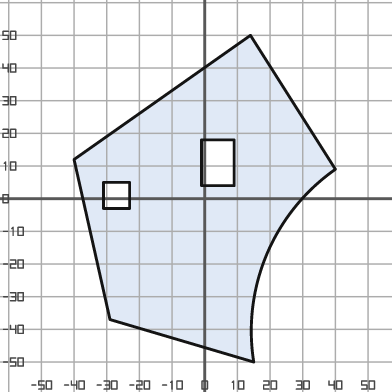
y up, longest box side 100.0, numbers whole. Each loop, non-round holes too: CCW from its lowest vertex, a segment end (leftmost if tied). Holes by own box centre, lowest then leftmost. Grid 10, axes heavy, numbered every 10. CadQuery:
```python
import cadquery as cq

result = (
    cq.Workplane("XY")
    .moveTo(15.0, -50.0)
    .threePointArc((19.0, -17.0), (40.0, 9.0))
    .lineTo(14.0, 50.0)
    .lineTo(-40.0, 12.0)
    .lineTo(-29.0, -37.0)
    .close()
    .moveTo(-31.0, -3.0)
    .lineTo(-23.0, -3.0)
    .lineTo(-23.0, 5.0)
    .lineTo(-31.0, 5.0)
    .close()
    .moveTo(-1.0, 4.0)
    .lineTo(9.0, 4.0)
    .lineTo(9.0, 18.0)
    .lineTo(-1.0, 18.0)
    .close()
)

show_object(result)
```